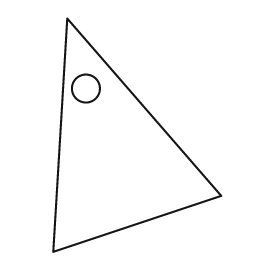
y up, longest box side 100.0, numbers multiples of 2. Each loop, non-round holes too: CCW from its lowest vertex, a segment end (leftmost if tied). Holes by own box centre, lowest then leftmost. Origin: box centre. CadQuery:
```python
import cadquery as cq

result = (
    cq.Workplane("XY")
    .moveTo(-36.0, -50.0)
    .lineTo(36.0, -26.0)
    .lineTo(-30.0, 50.0)
    .close()
    .moveTo(-22.0, 20.0)
    .circle(6.0)
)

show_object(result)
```